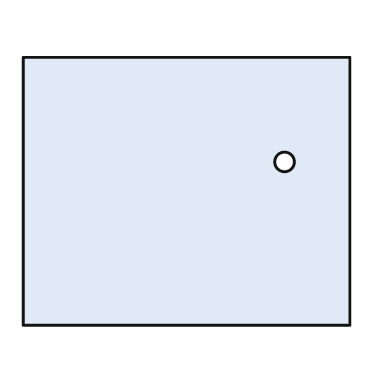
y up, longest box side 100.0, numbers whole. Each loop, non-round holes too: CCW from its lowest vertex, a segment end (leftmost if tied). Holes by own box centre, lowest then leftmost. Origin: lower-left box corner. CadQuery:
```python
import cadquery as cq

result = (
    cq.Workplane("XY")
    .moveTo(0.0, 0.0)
    .lineTo(100.0, 0.0)
    .lineTo(100.0, 82.0)
    .lineTo(0.0, 82.0)
    .close()
    .moveTo(80.0, 50.0)
    .circle(3.0)
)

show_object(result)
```